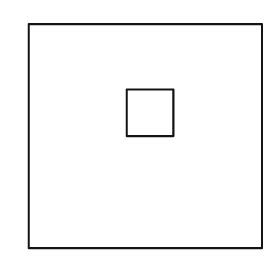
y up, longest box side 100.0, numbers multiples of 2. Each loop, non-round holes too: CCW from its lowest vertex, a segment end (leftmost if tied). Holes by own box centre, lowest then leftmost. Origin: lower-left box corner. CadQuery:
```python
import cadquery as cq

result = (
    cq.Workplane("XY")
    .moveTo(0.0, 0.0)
    .lineTo(100.0, 0.0)
    .lineTo(100.0, 96.0)
    .lineTo(0.0, 96.0)
    .close()
    .moveTo(42.0, 48.0)
    .lineTo(62.0, 48.0)
    .lineTo(62.0, 68.0)
    .lineTo(42.0, 68.0)
    .close()
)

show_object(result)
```